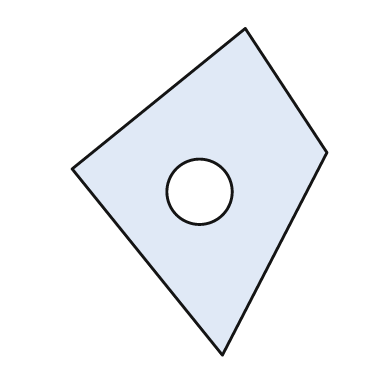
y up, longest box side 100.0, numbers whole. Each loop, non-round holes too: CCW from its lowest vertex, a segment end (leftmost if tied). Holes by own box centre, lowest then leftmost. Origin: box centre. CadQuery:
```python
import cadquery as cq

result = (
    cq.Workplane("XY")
    .moveTo(7.0, -50.0)
    .lineTo(39.0, 12.0)
    .lineTo(14.0, 50.0)
    .lineTo(-39.0, 7.0)
    .close()
    .moveTo(0.0, 0.0)
    .circle(10.0)
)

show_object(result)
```